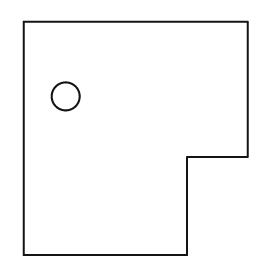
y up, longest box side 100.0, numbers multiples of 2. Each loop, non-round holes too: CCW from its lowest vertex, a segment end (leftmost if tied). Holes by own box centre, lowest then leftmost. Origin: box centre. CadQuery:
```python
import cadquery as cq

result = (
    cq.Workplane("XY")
    .moveTo(-48.0, -50.0)
    .lineTo(22.0, -50.0)
    .lineTo(22.0, -8.0)
    .lineTo(48.0, -8.0)
    .lineTo(48.0, 50.0)
    .lineTo(-48.0, 50.0)
    .close()
    .moveTo(-30.0, 18.0)
    .circle(6.0)
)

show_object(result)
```